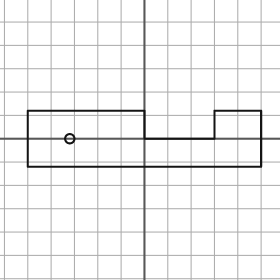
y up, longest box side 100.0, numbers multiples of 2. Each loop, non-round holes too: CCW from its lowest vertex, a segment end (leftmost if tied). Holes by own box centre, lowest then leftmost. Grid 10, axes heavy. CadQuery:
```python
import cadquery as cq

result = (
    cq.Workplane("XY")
    .moveTo(-50.0, -12.0)
    .lineTo(50.0, -12.0)
    .lineTo(50.0, 12.0)
    .lineTo(30.0, 12.0)
    .lineTo(30.0, 0.0)
    .lineTo(0.0, 0.0)
    .lineTo(0.0, 12.0)
    .lineTo(-50.0, 12.0)
    .close()
    .moveTo(-32.0, 0.0)
    .circle(2.0)
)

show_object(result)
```